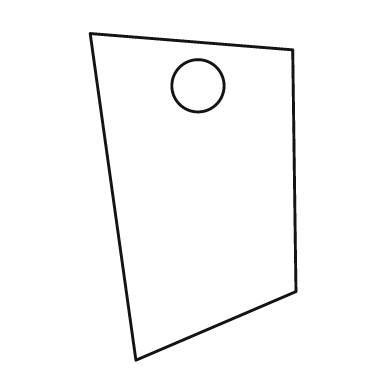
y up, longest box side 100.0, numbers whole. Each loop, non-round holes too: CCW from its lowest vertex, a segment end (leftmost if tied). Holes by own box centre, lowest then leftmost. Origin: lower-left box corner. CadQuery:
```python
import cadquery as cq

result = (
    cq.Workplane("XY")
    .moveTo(14.0, 0.0)
    .lineTo(63.0, 21.0)
    .lineTo(62.0, 95.0)
    .lineTo(0.0, 100.0)
    .close()
    .moveTo(33.0, 84.0)
    .circle(8.0)
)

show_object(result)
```